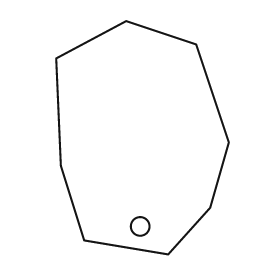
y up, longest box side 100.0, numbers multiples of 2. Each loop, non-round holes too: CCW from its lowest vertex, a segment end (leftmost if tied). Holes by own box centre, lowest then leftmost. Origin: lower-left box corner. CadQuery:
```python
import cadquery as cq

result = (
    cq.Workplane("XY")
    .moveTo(48.0, 0.0)
    .lineTo(66.0, 20.0)
    .lineTo(74.0, 48.0)
    .lineTo(60.0, 90.0)
    .lineTo(30.0, 100.0)
    .lineTo(0.0, 84.0)
    .lineTo(2.0, 38.0)
    .lineTo(12.0, 6.0)
    .close()
    .moveTo(36.0, 12.0)
    .circle(4.0)
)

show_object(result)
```